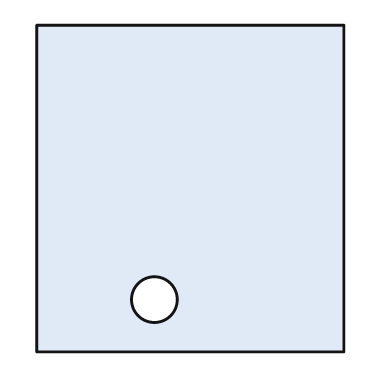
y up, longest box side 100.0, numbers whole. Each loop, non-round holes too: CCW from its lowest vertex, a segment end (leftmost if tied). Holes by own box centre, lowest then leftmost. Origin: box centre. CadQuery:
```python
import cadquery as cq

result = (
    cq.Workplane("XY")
    .moveTo(-47.0, -50.0)
    .lineTo(47.0, -50.0)
    .lineTo(47.0, 50.0)
    .lineTo(-47.0, 50.0)
    .close()
    .moveTo(-11.0, -34.0)
    .circle(7.0)
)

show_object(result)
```